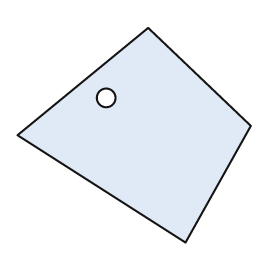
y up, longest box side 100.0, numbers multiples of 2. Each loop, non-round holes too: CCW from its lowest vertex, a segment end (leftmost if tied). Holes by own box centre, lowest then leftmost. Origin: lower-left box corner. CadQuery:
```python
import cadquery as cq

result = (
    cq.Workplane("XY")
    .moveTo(72.0, 0.0)
    .lineTo(100.0, 50.0)
    .lineTo(56.0, 92.0)
    .lineTo(0.0, 46.0)
    .close()
    .moveTo(38.0, 62.0)
    .circle(4.0)
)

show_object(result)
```